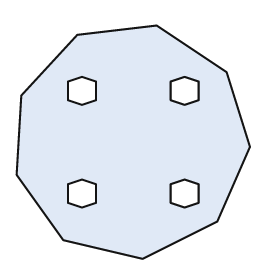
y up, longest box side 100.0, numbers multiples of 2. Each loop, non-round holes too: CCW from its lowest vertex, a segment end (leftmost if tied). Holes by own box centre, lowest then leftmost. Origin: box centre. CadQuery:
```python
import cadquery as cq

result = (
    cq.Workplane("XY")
    .moveTo(4.0, -50.0)
    .lineTo(36.0, -34.0)
    .lineTo(50.0, -2.0)
    .lineTo(40.0, 30.0)
    .lineTo(10.0, 50.0)
    .lineTo(-24.0, 46.0)
    .lineTo(-48.0, 20.0)
    .lineTo(-50.0, -14.0)
    .lineTo(-30.0, -42.0)
    .close()
    .moveTo(-22.0, -28.0)
    .lineTo(-16.0, -26.0)
    .lineTo(-16.0, -18.0)
    .lineTo(-22.0, -16.0)
    .lineTo(-28.0, -18.0)
    .lineTo(-28.0, -26.0)
    .close()
    .moveTo(22.0, -28.0)
    .lineTo(28.0, -26.0)
    .lineTo(28.0, -18.0)
    .lineTo(22.0, -16.0)
    .lineTo(16.0, -18.0)
    .lineTo(16.0, -26.0)
    .close()
    .moveTo(-22.0, 16.0)
    .lineTo(-16.0, 18.0)
    .lineTo(-16.0, 26.0)
    .lineTo(-22.0, 28.0)
    .lineTo(-28.0, 26.0)
    .lineTo(-28.0, 18.0)
    .close()
    .moveTo(22.0, 16.0)
    .lineTo(28.0, 18.0)
    .lineTo(28.0, 26.0)
    .lineTo(22.0, 28.0)
    .lineTo(16.0, 26.0)
    .lineTo(16.0, 18.0)
    .close()
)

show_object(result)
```